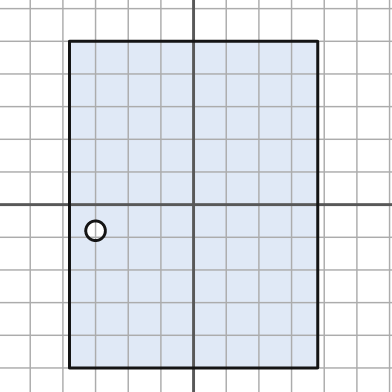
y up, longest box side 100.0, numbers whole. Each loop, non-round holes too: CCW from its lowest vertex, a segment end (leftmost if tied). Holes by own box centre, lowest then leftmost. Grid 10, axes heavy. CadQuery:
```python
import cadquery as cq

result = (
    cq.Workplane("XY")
    .moveTo(-38.0, -50.0)
    .lineTo(38.0, -50.0)
    .lineTo(38.0, 50.0)
    .lineTo(-38.0, 50.0)
    .close()
    .moveTo(-30.0, -8.0)
    .circle(3.0)
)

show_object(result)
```